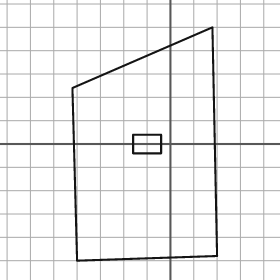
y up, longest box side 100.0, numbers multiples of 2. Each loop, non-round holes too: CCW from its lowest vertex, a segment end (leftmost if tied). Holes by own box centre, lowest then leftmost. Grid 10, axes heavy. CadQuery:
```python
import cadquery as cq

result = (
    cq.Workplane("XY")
    .moveTo(-40.0, -50.0)
    .lineTo(20.0, -48.0)
    .lineTo(18.0, 50.0)
    .lineTo(-42.0, 24.0)
    .close()
    .moveTo(-16.0, -4.0)
    .lineTo(-4.0, -4.0)
    .lineTo(-4.0, 4.0)
    .lineTo(-16.0, 4.0)
    .close()
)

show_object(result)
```